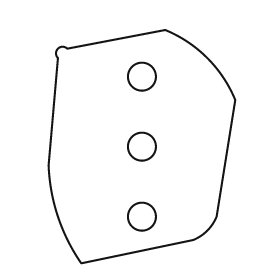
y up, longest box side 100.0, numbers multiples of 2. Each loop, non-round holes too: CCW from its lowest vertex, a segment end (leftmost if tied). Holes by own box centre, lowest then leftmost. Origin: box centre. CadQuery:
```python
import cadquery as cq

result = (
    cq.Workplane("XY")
    .moveTo(-26.0, -50.0)
    .lineTo(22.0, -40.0)
    .threePointArc((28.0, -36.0), (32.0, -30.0))
    .lineTo(40.0, 20.0)
    .threePointArc((28.0, 38.0), (10.0, 50.0))
    .lineTo(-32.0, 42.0)
    .threePointArc((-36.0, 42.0), (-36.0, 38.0))
    .lineTo(-40.0, -8.0)
    .threePointArc((-36.0, -30.0), (-26.0, -50.0))
    .close()
    .moveTo(0.0, -30.0)
    .circle(6.0)
    .moveTo(0.0, 0.0)
    .circle(6.0)
    .moveTo(0.0, 30.0)
    .circle(6.0)
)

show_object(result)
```